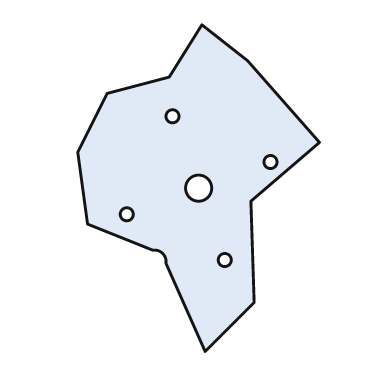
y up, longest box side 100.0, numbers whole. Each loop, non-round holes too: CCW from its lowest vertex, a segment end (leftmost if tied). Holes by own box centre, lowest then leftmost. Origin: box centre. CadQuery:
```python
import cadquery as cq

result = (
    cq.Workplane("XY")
    .moveTo(2.0, -50.0)
    .lineTo(17.0, -35.0)
    .lineTo(16.0, -4.0)
    .lineTo(37.0, 14.0)
    .lineTo(15.0, 39.0)
    .lineTo(1.0, 50.0)
    .lineTo(-9.0, 34.0)
    .lineTo(-28.0, 29.0)
    .lineTo(-37.0, 11.0)
    .lineTo(-34.0, -11.0)
    .lineTo(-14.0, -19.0)
    .threePointArc((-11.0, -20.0), (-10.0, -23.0))
    .close()
    .moveTo(8.0, -22.0)
    .circle(2.0)
    .moveTo(-22.0, -8.0)
    .circle(2.0)
    .moveTo(0.0, 0.0)
    .circle(4.0)
    .moveTo(22.0, 8.0)
    .circle(2.0)
    .moveTo(-8.0, 22.0)
    .circle(2.0)
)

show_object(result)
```